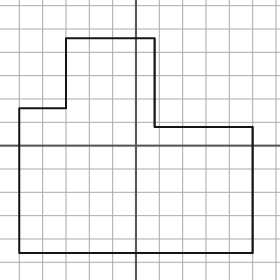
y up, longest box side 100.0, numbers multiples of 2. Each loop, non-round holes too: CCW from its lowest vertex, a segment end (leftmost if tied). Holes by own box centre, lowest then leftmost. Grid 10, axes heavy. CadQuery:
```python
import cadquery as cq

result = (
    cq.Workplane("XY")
    .moveTo(-50.0, -46.0)
    .lineTo(50.0, -46.0)
    .lineTo(50.0, 8.0)
    .lineTo(8.0, 8.0)
    .lineTo(8.0, 46.0)
    .lineTo(-30.0, 46.0)
    .lineTo(-30.0, 16.0)
    .lineTo(-50.0, 16.0)
    .close()
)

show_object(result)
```